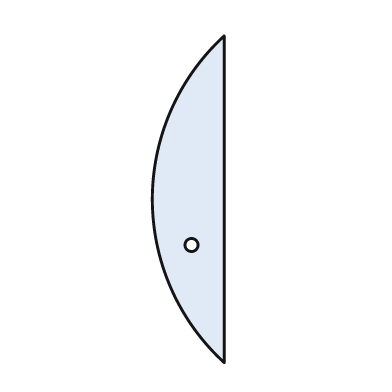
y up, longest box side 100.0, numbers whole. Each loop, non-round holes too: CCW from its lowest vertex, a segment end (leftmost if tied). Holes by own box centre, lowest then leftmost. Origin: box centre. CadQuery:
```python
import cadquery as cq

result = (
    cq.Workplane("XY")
    .moveTo(11.0, -50.0)
    .lineTo(11.0, 50.0)
    .threePointArc((-11.0, 0.0), (11.0, -50.0))
    .close()
    .moveTo(1.0, -14.0)
    .circle(2.0)
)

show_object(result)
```